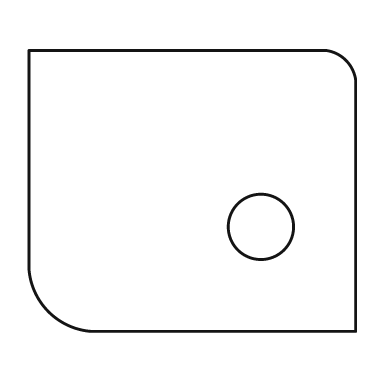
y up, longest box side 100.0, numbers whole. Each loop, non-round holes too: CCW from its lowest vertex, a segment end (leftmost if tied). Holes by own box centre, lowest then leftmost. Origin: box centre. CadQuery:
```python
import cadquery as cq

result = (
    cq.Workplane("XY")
    .moveTo(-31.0, -43.0)
    .lineTo(50.0, -43.0)
    .lineTo(50.0, 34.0)
    .threePointArc((47.0, 40.0), (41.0, 43.0))
    .lineTo(-50.0, 43.0)
    .lineTo(-50.0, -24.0)
    .threePointArc((-44.0, -37.0), (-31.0, -43.0))
    .close()
    .moveTo(21.0, -11.0)
    .circle(10.0)
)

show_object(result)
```